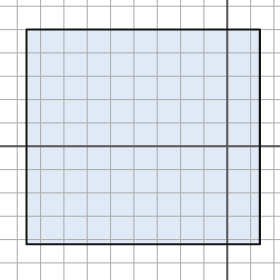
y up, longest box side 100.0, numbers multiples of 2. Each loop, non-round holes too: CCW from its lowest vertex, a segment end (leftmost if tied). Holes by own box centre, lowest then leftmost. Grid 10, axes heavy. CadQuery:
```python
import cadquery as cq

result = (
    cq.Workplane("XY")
    .moveTo(-86.0, -42.0)
    .lineTo(14.0, -42.0)
    .lineTo(14.0, 50.0)
    .lineTo(-86.0, 50.0)
    .close()
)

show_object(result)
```